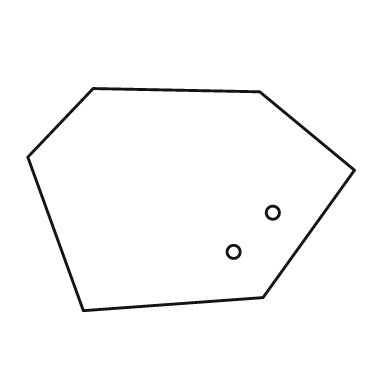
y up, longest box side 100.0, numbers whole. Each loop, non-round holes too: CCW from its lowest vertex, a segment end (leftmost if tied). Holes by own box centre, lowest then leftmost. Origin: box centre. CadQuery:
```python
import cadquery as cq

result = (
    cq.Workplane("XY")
    .moveTo(-33.0, -34.0)
    .lineTo(22.0, -30.0)
    .lineTo(50.0, 9.0)
    .lineTo(21.0, 33.0)
    .lineTo(-30.0, 34.0)
    .lineTo(-50.0, 13.0)
    .close()
    .moveTo(13.0, -16.0)
    .circle(2.0)
    .moveTo(25.0, -4.0)
    .circle(2.0)
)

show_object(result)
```